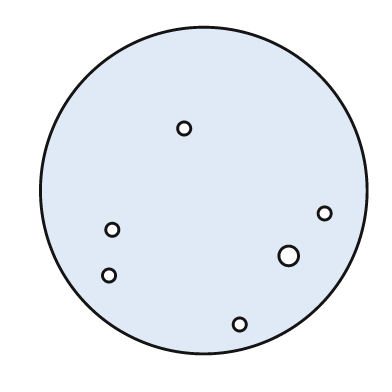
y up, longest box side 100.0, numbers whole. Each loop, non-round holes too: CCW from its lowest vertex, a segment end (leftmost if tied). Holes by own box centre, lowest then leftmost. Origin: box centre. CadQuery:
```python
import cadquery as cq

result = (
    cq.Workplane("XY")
    .moveTo(0.0, 0.0)
    .circle(50.0)
    .moveTo(11.0, -41.0)
    .circle(2.0)
    .moveTo(-29.0, -26.0)
    .circle(2.0)
    .moveTo(26.0, -20.0)
    .circle(3.0)
    .moveTo(-28.0, -12.0)
    .circle(2.0)
    .moveTo(37.0, -7.0)
    .circle(2.0)
    .moveTo(-6.0, 19.0)
    .circle(2.0)
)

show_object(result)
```